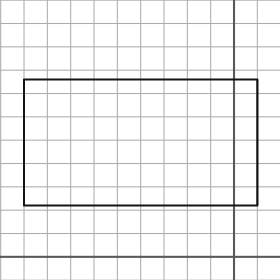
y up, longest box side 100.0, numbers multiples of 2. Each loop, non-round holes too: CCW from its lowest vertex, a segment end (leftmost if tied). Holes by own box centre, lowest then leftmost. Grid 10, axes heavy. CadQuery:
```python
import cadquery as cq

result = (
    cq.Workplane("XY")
    .moveTo(-90.0, 22.0)
    .lineTo(10.0, 22.0)
    .lineTo(10.0, 76.0)
    .lineTo(-90.0, 76.0)
    .close()
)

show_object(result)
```